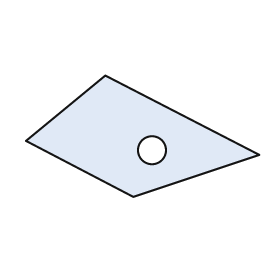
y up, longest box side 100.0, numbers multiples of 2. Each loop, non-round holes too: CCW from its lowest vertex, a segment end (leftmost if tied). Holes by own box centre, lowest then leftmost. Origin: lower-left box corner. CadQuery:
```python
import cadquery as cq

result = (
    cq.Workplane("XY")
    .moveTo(46.0, 0.0)
    .lineTo(100.0, 18.0)
    .lineTo(34.0, 52.0)
    .lineTo(0.0, 24.0)
    .close()
    .moveTo(54.0, 20.0)
    .circle(6.0)
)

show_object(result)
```